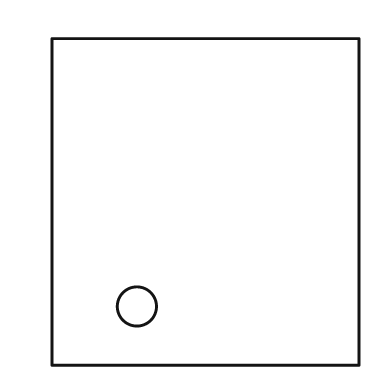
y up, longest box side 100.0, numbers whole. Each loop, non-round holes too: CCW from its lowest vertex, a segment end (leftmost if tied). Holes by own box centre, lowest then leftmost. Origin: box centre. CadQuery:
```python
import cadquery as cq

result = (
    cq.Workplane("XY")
    .moveTo(-47.0, -50.0)
    .lineTo(47.0, -50.0)
    .lineTo(47.0, 50.0)
    .lineTo(-47.0, 50.0)
    .close()
    .moveTo(-21.0, -32.0)
    .circle(6.0)
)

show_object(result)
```